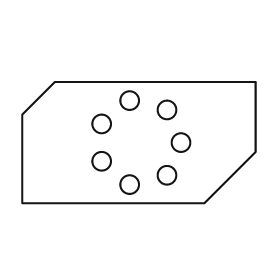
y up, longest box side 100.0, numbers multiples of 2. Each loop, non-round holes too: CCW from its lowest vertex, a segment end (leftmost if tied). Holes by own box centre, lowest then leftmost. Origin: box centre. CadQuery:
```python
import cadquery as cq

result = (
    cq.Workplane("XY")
    .moveTo(-50.0, -26.0)
    .lineTo(28.0, -26.0)
    .lineTo(50.0, -4.0)
    .lineTo(50.0, 26.0)
    .lineTo(-36.0, 26.0)
    .lineTo(-50.0, 12.0)
    .close()
    .moveTo(-4.0, -18.0)
    .circle(4.0)
    .moveTo(12.0, -14.0)
    .circle(4.0)
    .moveTo(-16.0, -8.0)
    .circle(4.0)
    .moveTo(18.0, 0.0)
    .circle(4.0)
    .moveTo(-16.0, 8.0)
    .circle(4.0)
    .moveTo(12.0, 14.0)
    .circle(4.0)
    .moveTo(-4.0, 18.0)
    .circle(4.0)
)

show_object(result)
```